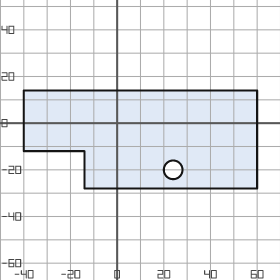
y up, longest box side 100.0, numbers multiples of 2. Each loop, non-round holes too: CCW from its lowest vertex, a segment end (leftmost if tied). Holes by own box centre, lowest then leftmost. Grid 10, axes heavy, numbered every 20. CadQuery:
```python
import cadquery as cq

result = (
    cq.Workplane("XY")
    .moveTo(-14.0, -28.0)
    .lineTo(60.0, -28.0)
    .lineTo(60.0, 14.0)
    .lineTo(-40.0, 14.0)
    .lineTo(-40.0, -12.0)
    .lineTo(-14.0, -12.0)
    .close()
    .moveTo(24.0, -20.0)
    .circle(4.0)
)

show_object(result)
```